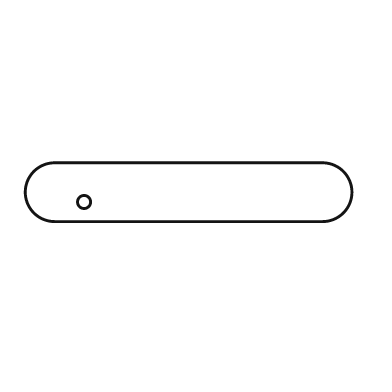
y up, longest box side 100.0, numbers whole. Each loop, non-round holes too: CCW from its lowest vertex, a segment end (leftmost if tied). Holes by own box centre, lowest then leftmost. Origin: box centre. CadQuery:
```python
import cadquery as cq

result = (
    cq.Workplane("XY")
    .moveTo(-41.0, -9.0)
    .lineTo(41.0, -9.0)
    .threePointArc((50.0, 0.0), (41.0, 9.0))
    .lineTo(-41.0, 9.0)
    .threePointArc((-50.0, 0.0), (-41.0, -9.0))
    .close()
    .moveTo(-32.0, -3.0)
    .circle(2.0)
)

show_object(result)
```